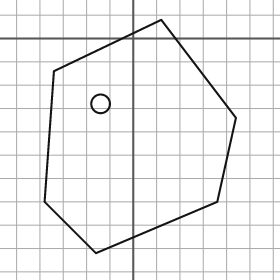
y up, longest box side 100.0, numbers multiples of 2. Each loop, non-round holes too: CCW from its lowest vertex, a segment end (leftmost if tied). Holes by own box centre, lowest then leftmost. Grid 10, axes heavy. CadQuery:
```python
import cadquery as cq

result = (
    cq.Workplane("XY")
    .moveTo(-16.0, -92.0)
    .lineTo(36.0, -70.0)
    .lineTo(44.0, -34.0)
    .lineTo(12.0, 8.0)
    .lineTo(-34.0, -14.0)
    .lineTo(-38.0, -70.0)
    .close()
    .moveTo(-14.0, -28.0)
    .circle(4.0)
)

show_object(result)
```